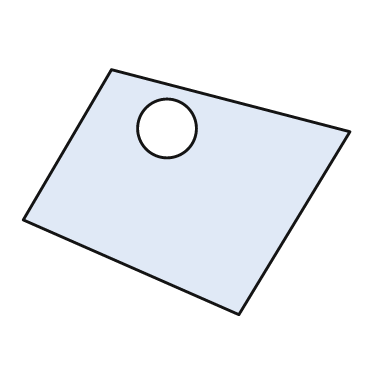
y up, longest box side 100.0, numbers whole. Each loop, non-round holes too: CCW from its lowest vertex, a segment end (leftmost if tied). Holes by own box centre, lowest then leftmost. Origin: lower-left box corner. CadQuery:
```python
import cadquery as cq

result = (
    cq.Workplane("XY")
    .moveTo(66.0, 0.0)
    .lineTo(100.0, 56.0)
    .lineTo(27.0, 75.0)
    .lineTo(0.0, 29.0)
    .close()
    .moveTo(44.0, 57.0)
    .circle(9.0)
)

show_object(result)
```